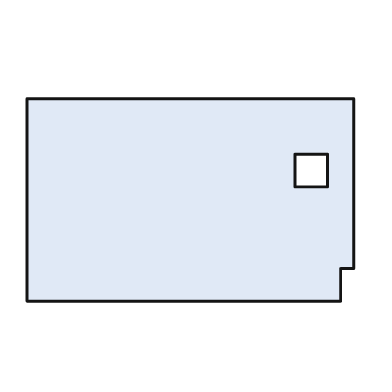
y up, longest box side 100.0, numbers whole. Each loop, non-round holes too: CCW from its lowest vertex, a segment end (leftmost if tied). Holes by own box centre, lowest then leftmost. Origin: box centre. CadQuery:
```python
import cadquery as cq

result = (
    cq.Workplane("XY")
    .moveTo(-50.0, -31.0)
    .lineTo(46.0, -31.0)
    .lineTo(46.0, -21.0)
    .lineTo(50.0, -21.0)
    .lineTo(50.0, 31.0)
    .lineTo(-50.0, 31.0)
    .close()
    .moveTo(32.0, 4.0)
    .lineTo(42.0, 4.0)
    .lineTo(42.0, 14.0)
    .lineTo(32.0, 14.0)
    .close()
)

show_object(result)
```